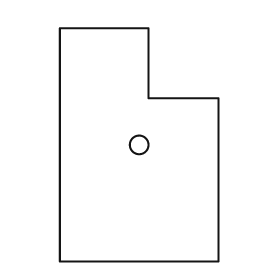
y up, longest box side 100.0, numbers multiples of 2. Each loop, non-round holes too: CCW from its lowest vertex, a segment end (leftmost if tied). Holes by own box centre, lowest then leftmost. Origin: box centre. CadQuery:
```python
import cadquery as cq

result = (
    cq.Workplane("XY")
    .moveTo(-34.0, -50.0)
    .lineTo(34.0, -50.0)
    .lineTo(34.0, 20.0)
    .lineTo(4.0, 20.0)
    .lineTo(4.0, 50.0)
    .lineTo(-34.0, 50.0)
    .close()
    .moveTo(0.0, 0.0)
    .circle(4.0)
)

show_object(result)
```